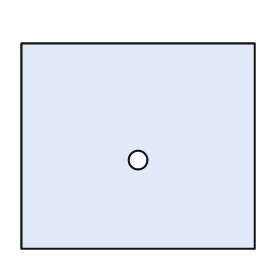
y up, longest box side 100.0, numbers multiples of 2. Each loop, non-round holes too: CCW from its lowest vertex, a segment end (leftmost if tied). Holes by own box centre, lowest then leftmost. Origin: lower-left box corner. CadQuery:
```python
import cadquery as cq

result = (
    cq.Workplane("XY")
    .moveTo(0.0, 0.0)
    .lineTo(100.0, 0.0)
    .lineTo(100.0, 88.0)
    .lineTo(0.0, 88.0)
    .close()
    .moveTo(50.0, 38.0)
    .circle(4.0)
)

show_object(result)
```